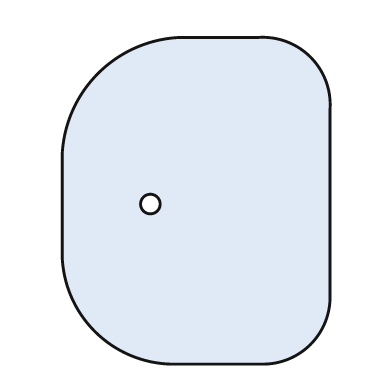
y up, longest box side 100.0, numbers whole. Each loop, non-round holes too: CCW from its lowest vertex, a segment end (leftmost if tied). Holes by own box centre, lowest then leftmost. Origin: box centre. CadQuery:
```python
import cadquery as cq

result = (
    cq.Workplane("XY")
    .moveTo(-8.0, -50.0)
    .lineTo(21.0, -50.0)
    .threePointArc((35.0, -44.0), (41.0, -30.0))
    .lineTo(41.0, 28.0)
    .threePointArc((35.0, 44.0), (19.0, 50.0))
    .lineTo(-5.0, 50.0)
    .threePointArc((-30.0, 39.0), (-41.0, 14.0))
    .lineTo(-41.0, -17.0)
    .threePointArc((-31.0, -40.0), (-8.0, -50.0))
    .close()
    .moveTo(-14.0, -1.0)
    .circle(3.0)
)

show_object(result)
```